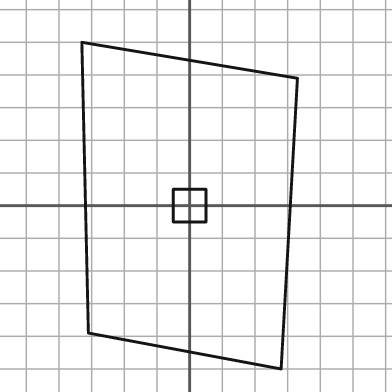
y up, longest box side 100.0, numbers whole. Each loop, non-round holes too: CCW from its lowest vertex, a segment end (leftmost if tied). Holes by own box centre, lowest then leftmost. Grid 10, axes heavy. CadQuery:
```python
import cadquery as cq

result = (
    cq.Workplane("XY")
    .moveTo(28.0, -50.0)
    .lineTo(33.0, 39.0)
    .lineTo(-33.0, 50.0)
    .lineTo(-31.0, -39.0)
    .close()
    .moveTo(-5.0, -5.0)
    .lineTo(5.0, -5.0)
    .lineTo(5.0, 5.0)
    .lineTo(-5.0, 5.0)
    .close()
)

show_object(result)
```